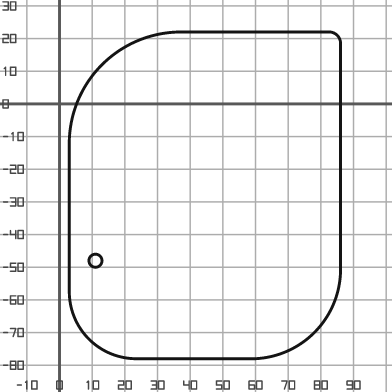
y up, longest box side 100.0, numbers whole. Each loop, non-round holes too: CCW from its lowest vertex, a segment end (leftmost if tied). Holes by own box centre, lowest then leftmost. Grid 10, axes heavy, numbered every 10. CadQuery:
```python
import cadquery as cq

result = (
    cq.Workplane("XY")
    .moveTo(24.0, -78.0)
    .lineTo(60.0, -78.0)
    .threePointArc((78.0, -70.0), (86.0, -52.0))
    .lineTo(86.0, 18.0)
    .threePointArc((85.0, 21.0), (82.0, 22.0))
    .lineTo(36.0, 22.0)
    .threePointArc((13.0, 12.0), (3.0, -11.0))
    .lineTo(3.0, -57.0)
    .threePointArc((9.0, -72.0), (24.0, -78.0))
    .close()
    .moveTo(11.0, -48.0)
    .circle(2.0)
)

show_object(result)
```